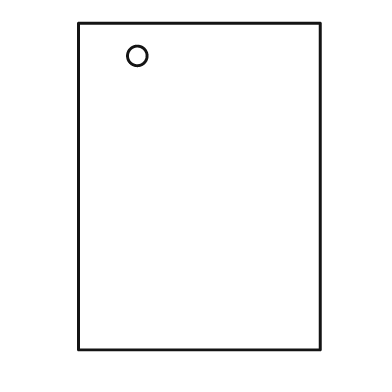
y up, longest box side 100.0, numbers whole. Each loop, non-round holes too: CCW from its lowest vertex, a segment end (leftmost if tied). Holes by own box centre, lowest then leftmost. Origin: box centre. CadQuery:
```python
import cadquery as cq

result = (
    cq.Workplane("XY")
    .moveTo(-37.0, -50.0)
    .lineTo(37.0, -50.0)
    .lineTo(37.0, 50.0)
    .lineTo(-37.0, 50.0)
    .close()
    .moveTo(-19.0, 40.0)
    .circle(3.0)
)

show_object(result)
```